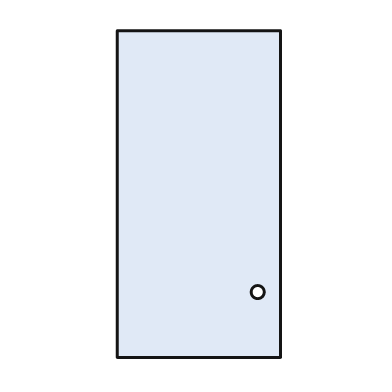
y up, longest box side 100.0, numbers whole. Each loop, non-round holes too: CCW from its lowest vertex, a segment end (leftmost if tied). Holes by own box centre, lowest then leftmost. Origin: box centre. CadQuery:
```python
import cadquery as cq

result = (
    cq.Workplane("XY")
    .moveTo(-25.0, -50.0)
    .lineTo(25.0, -50.0)
    .lineTo(25.0, 50.0)
    .lineTo(-25.0, 50.0)
    .close()
    .moveTo(18.0, -30.0)
    .circle(2.0)
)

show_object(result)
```